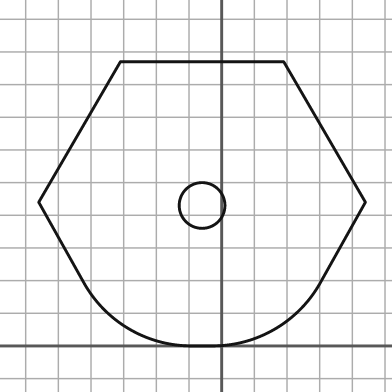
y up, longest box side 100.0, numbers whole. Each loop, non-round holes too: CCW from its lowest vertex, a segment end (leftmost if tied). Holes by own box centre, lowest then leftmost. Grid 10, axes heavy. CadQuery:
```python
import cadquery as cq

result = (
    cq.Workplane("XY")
    .moveTo(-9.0, 0.0)
    .lineTo(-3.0, 0.0)
    .threePointArc((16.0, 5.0), (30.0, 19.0))
    .lineTo(44.0, 44.0)
    .lineTo(19.0, 87.0)
    .lineTo(-31.0, 87.0)
    .lineTo(-56.0, 44.0)
    .lineTo(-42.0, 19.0)
    .threePointArc((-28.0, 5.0), (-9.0, 0.0))
    .close()
    .moveTo(-6.0, 43.0)
    .circle(7.0)
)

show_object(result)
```